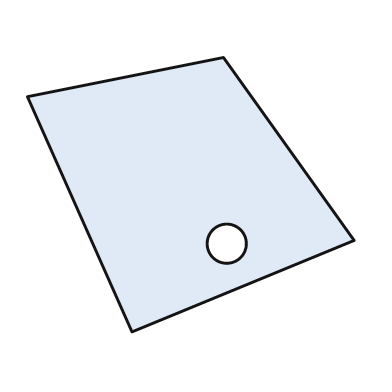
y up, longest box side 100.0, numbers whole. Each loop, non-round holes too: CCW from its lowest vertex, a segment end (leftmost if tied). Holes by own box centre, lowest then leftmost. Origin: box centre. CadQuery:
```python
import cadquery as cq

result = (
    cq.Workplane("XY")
    .moveTo(-18.0, -42.0)
    .lineTo(50.0, -14.0)
    .lineTo(10.0, 42.0)
    .lineTo(-50.0, 30.0)
    .close()
    .moveTo(11.0, -15.0)
    .circle(6.0)
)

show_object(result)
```